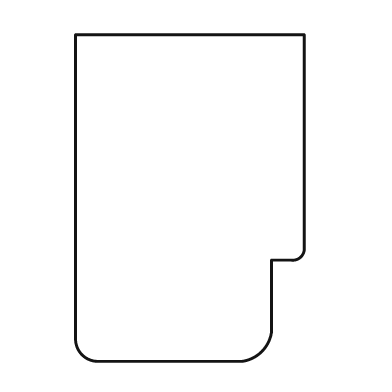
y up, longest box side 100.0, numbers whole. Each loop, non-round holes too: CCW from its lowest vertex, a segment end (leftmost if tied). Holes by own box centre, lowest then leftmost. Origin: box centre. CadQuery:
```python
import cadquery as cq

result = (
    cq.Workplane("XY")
    .moveTo(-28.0, -50.0)
    .lineTo(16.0, -50.0)
    .threePointArc((22.0, -47.0), (25.0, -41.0))
    .lineTo(25.0, -19.0)
    .lineTo(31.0, -19.0)
    .threePointArc((34.0, -18.0), (35.0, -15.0))
    .lineTo(35.0, 50.0)
    .lineTo(-35.0, 50.0)
    .lineTo(-35.0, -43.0)
    .threePointArc((-33.0, -48.0), (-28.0, -50.0))
    .close()
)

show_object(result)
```